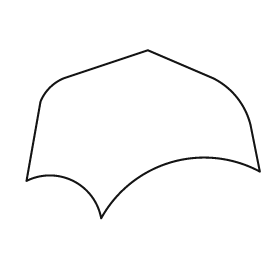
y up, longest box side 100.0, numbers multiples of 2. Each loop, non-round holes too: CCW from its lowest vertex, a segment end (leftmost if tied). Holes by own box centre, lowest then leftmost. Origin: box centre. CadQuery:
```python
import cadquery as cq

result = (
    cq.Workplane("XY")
    .moveTo(-18.0, -36.0)
    .threePointArc((12.0, -12.0), (50.0, -16.0))
    .lineTo(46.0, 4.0)
    .threePointArc((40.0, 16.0), (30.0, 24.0))
    .lineTo(2.0, 36.0)
    .lineTo(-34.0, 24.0)
    .threePointArc((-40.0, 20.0), (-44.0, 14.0))
    .lineTo(-50.0, -20.0)
    .threePointArc((-30.0, -20.0), (-18.0, -36.0))
    .close()
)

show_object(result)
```